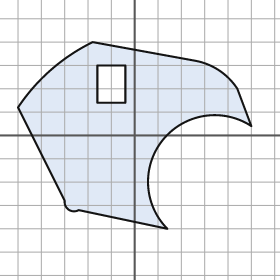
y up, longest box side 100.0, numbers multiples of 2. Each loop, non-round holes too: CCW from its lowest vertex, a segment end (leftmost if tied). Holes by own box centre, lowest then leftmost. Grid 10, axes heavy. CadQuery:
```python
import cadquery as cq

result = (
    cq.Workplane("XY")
    .moveTo(14.0, -40.0)
    .threePointArc((12.0, -2.0), (50.0, 4.0))
    .lineTo(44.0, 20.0)
    .threePointArc((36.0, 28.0), (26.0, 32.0))
    .lineTo(-18.0, 40.0)
    .threePointArc((-36.0, 28.0), (-50.0, 12.0))
    .lineTo(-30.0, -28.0)
    .threePointArc((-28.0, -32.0), (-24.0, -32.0))
    .close()
    .moveTo(-16.0, 14.0)
    .lineTo(-4.0, 14.0)
    .lineTo(-4.0, 30.0)
    .lineTo(-16.0, 30.0)
    .close()
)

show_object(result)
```